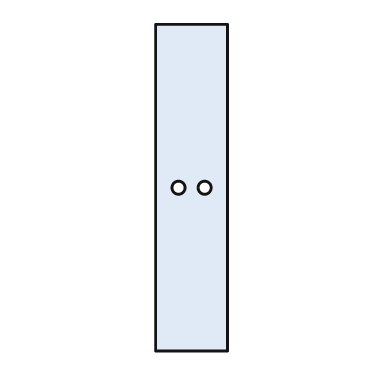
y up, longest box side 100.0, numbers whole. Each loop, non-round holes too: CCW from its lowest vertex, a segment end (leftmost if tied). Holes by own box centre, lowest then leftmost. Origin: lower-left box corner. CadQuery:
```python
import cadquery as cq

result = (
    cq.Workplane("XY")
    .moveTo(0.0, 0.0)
    .lineTo(22.0, 0.0)
    .lineTo(22.0, 100.0)
    .lineTo(0.0, 100.0)
    .close()
    .moveTo(7.0, 50.0)
    .circle(2.0)
    .moveTo(15.0, 50.0)
    .circle(2.0)
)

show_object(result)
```